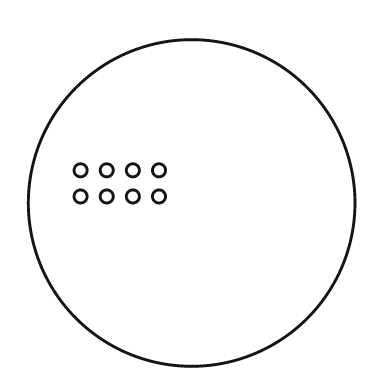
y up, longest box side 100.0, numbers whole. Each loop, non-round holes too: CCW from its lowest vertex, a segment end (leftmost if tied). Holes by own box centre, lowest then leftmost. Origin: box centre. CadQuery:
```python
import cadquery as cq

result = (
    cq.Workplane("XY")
    .moveTo(0.0, 0.0)
    .circle(50.0)
    .moveTo(-34.0, 2.0)
    .circle(2.0)
    .moveTo(-26.0, 2.0)
    .circle(2.0)
    .moveTo(-18.0, 2.0)
    .circle(2.0)
    .moveTo(-10.0, 2.0)
    .circle(2.0)
    .moveTo(-34.0, 10.0)
    .circle(2.0)
    .moveTo(-26.0, 10.0)
    .circle(2.0)
    .moveTo(-18.0, 10.0)
    .circle(2.0)
    .moveTo(-10.0, 10.0)
    .circle(2.0)
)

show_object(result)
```